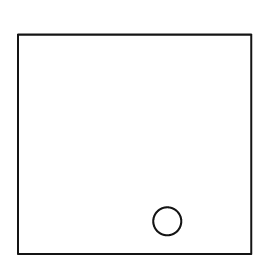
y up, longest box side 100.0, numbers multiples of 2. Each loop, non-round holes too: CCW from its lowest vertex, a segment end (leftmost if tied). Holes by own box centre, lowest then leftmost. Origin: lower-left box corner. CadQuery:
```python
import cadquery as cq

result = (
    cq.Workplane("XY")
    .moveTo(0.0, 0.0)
    .lineTo(100.0, 0.0)
    .lineTo(100.0, 94.0)
    .lineTo(0.0, 94.0)
    .close()
    .moveTo(64.0, 14.0)
    .circle(6.0)
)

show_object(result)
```